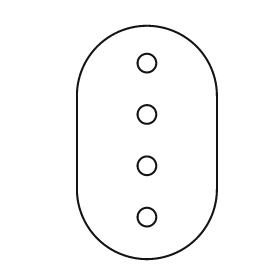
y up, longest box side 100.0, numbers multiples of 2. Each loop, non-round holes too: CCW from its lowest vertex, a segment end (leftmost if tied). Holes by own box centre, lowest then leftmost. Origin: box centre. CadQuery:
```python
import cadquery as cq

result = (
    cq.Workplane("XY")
    .moveTo(-30.0, -20.0)
    .threePointArc((0.0, -50.0), (30.0, -20.0))
    .lineTo(30.0, 20.0)
    .threePointArc((0.0, 50.0), (-30.0, 20.0))
    .close()
    .moveTo(0.0, -32.0)
    .circle(4.0)
    .moveTo(0.0, -10.0)
    .circle(4.0)
    .moveTo(0.0, 12.0)
    .circle(4.0)
    .moveTo(0.0, 34.0)
    .circle(4.0)
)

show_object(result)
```